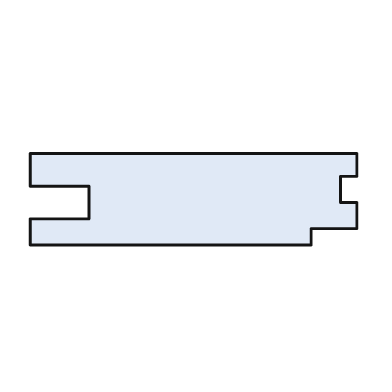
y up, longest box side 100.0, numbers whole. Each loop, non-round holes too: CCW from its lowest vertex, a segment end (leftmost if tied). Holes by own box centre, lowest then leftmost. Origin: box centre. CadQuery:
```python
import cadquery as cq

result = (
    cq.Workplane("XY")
    .moveTo(-50.0, -14.0)
    .lineTo(36.0, -14.0)
    .lineTo(36.0, -9.0)
    .lineTo(50.0, -9.0)
    .lineTo(50.0, -1.0)
    .lineTo(45.0, -1.0)
    .lineTo(45.0, 7.0)
    .lineTo(50.0, 7.0)
    .lineTo(50.0, 14.0)
    .lineTo(-50.0, 14.0)
    .lineTo(-50.0, 4.0)
    .lineTo(-32.0, 4.0)
    .lineTo(-32.0, -6.0)
    .lineTo(-50.0, -6.0)
    .close()
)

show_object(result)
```